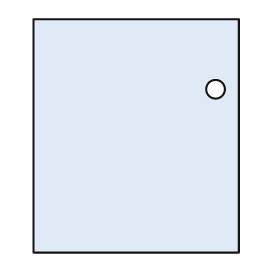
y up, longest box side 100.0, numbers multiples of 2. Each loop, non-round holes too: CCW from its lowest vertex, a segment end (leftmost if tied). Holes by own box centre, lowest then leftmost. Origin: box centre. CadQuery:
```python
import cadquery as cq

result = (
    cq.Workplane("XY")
    .moveTo(-44.0, -50.0)
    .lineTo(44.0, -50.0)
    .lineTo(44.0, 50.0)
    .lineTo(-44.0, 50.0)
    .close()
    .moveTo(34.0, 20.0)
    .circle(4.0)
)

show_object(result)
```